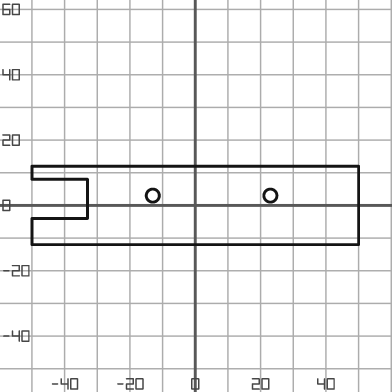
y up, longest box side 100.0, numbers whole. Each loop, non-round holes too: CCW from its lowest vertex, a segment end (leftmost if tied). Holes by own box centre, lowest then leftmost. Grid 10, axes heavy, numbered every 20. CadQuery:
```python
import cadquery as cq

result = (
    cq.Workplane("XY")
    .moveTo(-50.0, -12.0)
    .lineTo(50.0, -12.0)
    .lineTo(50.0, 12.0)
    .lineTo(-50.0, 12.0)
    .lineTo(-50.0, 8.0)
    .lineTo(-33.0, 8.0)
    .lineTo(-33.0, -4.0)
    .lineTo(-50.0, -4.0)
    .close()
    .moveTo(-13.0, 3.0)
    .circle(2.0)
    .moveTo(23.0, 3.0)
    .circle(2.0)
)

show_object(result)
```